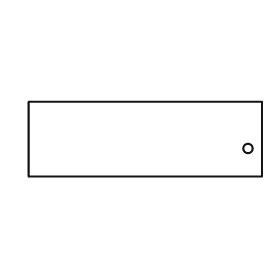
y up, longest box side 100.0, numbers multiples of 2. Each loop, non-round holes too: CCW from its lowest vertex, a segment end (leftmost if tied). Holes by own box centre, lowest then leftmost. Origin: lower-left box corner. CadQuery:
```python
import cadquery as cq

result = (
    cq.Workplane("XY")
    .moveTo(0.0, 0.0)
    .lineTo(100.0, 0.0)
    .lineTo(100.0, 32.0)
    .lineTo(0.0, 32.0)
    .close()
    .moveTo(94.0, 12.0)
    .circle(2.0)
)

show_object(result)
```